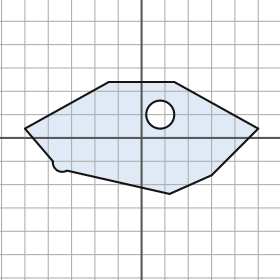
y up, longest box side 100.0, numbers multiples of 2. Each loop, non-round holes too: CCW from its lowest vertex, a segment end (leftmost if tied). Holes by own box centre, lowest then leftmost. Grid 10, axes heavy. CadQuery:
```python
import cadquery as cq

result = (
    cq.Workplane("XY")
    .moveTo(12.0, -24.0)
    .lineTo(30.0, -16.0)
    .lineTo(50.0, 4.0)
    .lineTo(14.0, 24.0)
    .lineTo(-14.0, 24.0)
    .lineTo(-50.0, 4.0)
    .lineTo(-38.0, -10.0)
    .threePointArc((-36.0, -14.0), (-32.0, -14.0))
    .close()
    .moveTo(8.0, 10.0)
    .circle(6.0)
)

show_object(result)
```